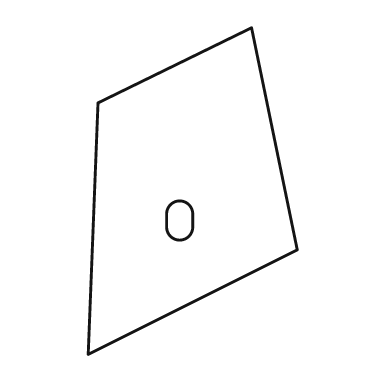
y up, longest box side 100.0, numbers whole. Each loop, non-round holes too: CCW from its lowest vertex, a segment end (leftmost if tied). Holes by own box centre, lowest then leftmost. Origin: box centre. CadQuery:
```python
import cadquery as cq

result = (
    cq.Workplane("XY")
    .moveTo(-32.0, -50.0)
    .lineTo(32.0, -18.0)
    .lineTo(18.0, 50.0)
    .lineTo(-29.0, 27.0)
    .close()
    .moveTo(-8.0, -11.0)
    .threePointArc((-4.0, -15.0), (0.0, -11.0))
    .lineTo(0.0, -7.0)
    .threePointArc((-4.0, -3.0), (-8.0, -7.0))
    .close()
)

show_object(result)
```